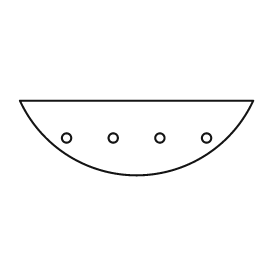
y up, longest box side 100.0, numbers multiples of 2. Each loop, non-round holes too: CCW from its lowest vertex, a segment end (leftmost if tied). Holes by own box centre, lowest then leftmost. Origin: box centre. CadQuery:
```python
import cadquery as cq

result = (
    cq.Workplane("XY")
    .moveTo(-50.0, 16.0)
    .threePointArc((0.0, -16.0), (50.0, 16.0))
    .close()
    .moveTo(-30.0, 0.0)
    .circle(2.0)
    .moveTo(-10.0, 0.0)
    .circle(2.0)
    .moveTo(10.0, 0.0)
    .circle(2.0)
    .moveTo(30.0, 0.0)
    .circle(2.0)
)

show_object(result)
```